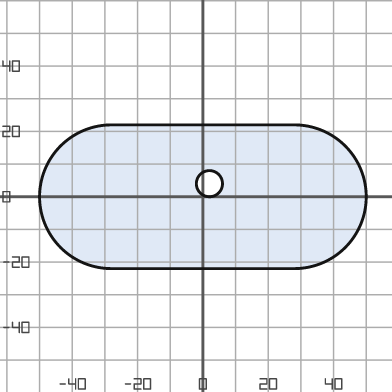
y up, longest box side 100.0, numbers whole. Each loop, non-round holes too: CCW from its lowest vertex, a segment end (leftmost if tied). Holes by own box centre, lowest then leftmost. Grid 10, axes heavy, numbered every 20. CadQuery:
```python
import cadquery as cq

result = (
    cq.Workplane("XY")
    .moveTo(-28.0, -22.0)
    .lineTo(28.0, -22.0)
    .threePointArc((50.0, 0.0), (28.0, 22.0))
    .lineTo(-28.0, 22.0)
    .threePointArc((-50.0, 0.0), (-28.0, -22.0))
    .close()
    .moveTo(2.0, 4.0)
    .circle(4.0)
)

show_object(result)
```